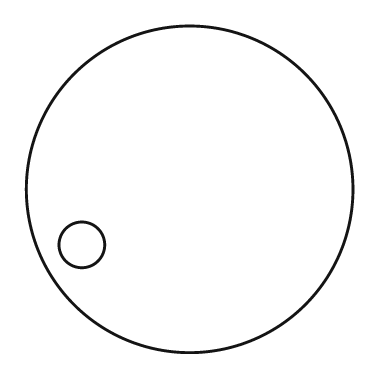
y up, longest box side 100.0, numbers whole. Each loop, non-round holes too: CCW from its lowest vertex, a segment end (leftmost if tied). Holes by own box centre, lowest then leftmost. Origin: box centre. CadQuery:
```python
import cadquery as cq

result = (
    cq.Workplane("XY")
    .moveTo(0.0, 0.0)
    .circle(50.0)
    .moveTo(-33.0, -17.0)
    .circle(7.0)
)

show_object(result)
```